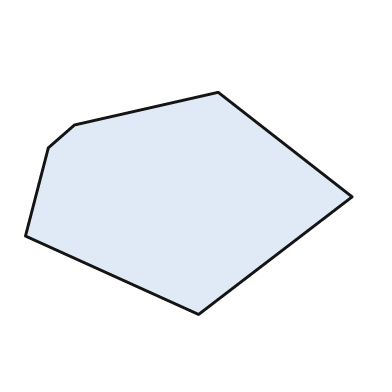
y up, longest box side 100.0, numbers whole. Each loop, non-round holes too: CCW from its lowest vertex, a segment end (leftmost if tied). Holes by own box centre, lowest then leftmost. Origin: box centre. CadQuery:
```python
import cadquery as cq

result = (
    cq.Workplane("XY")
    .moveTo(3.0, -34.0)
    .lineTo(50.0, 2.0)
    .lineTo(9.0, 34.0)
    .lineTo(-35.0, 24.0)
    .lineTo(-43.0, 17.0)
    .lineTo(-50.0, -10.0)
    .close()
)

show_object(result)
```